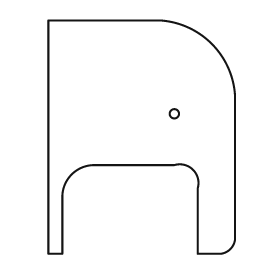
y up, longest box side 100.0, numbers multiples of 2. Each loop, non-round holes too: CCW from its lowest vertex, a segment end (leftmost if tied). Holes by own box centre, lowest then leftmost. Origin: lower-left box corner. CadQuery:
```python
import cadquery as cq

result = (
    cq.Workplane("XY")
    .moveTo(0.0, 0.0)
    .lineTo(6.0, 0.0)
    .lineTo(6.0, 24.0)
    .threePointArc((10.0, 34.0), (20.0, 38.0))
    .lineTo(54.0, 38.0)
    .threePointArc((62.0, 36.0), (64.0, 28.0))
    .lineTo(64.0, 0.0)
    .lineTo(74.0, 0.0)
    .threePointArc((78.0, 2.0), (80.0, 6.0))
    .lineTo(80.0, 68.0)
    .threePointArc((70.0, 90.0), (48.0, 100.0))
    .lineTo(0.0, 100.0)
    .close()
    .moveTo(54.0, 60.0)
    .circle(2.0)
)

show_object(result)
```